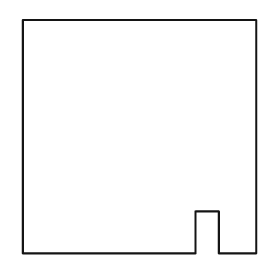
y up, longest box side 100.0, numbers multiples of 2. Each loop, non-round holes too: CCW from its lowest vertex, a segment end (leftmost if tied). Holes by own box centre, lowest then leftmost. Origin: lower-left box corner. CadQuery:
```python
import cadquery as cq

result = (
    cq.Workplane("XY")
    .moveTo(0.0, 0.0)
    .lineTo(74.0, 0.0)
    .lineTo(74.0, 18.0)
    .lineTo(84.0, 18.0)
    .lineTo(84.0, 0.0)
    .lineTo(100.0, 0.0)
    .lineTo(100.0, 100.0)
    .lineTo(0.0, 100.0)
    .close()
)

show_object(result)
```